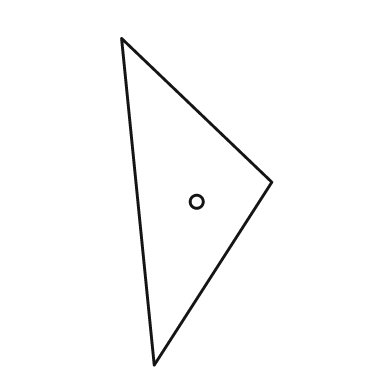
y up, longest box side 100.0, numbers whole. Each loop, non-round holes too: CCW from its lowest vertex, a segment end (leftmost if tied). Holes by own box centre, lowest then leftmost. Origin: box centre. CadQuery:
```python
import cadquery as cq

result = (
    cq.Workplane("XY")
    .moveTo(-13.0, -50.0)
    .lineTo(23.0, 6.0)
    .lineTo(-23.0, 50.0)
    .close()
    .moveTo(0.0, 0.0)
    .circle(2.0)
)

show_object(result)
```